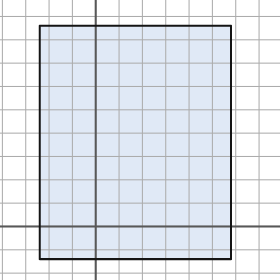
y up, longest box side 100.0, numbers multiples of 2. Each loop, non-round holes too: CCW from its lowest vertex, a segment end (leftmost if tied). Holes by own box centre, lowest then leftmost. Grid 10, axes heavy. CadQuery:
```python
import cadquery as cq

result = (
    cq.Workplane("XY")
    .moveTo(-24.0, -14.0)
    .lineTo(58.0, -14.0)
    .lineTo(58.0, 86.0)
    .lineTo(-24.0, 86.0)
    .close()
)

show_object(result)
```